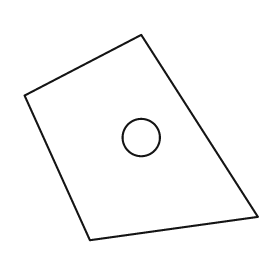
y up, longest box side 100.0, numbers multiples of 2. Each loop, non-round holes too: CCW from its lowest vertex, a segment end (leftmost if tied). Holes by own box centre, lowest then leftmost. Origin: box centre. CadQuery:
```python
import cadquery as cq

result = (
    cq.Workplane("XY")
    .moveTo(-22.0, -44.0)
    .lineTo(50.0, -34.0)
    .lineTo(0.0, 44.0)
    .lineTo(-50.0, 18.0)
    .close()
    .moveTo(0.0, 0.0)
    .circle(8.0)
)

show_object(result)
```